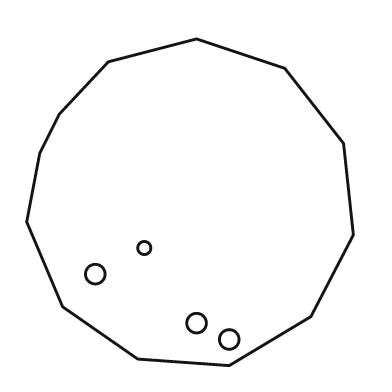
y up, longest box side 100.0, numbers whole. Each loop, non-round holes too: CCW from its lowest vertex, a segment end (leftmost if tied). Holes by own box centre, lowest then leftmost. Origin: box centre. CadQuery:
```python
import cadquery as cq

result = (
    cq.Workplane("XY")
    .moveTo(12.0, -50.0)
    .lineTo(37.0, -35.0)
    .lineTo(50.0, -10.0)
    .lineTo(47.0, 18.0)
    .lineTo(29.0, 41.0)
    .lineTo(2.0, 50.0)
    .lineTo(-25.0, 43.0)
    .lineTo(-40.0, 27.0)
    .lineTo(-46.0, 15.0)
    .lineTo(-50.0, -6.0)
    .lineTo(-39.0, -32.0)
    .lineTo(-16.0, -48.0)
    .close()
    .moveTo(12.0, -42.0)
    .circle(3.0)
    .moveTo(2.0, -37.0)
    .circle(3.0)
    .moveTo(-29.0, -22.0)
    .circle(3.0)
    .moveTo(-14.0, -14.0)
    .circle(2.0)
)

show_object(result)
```